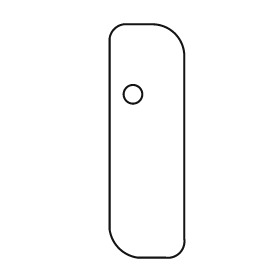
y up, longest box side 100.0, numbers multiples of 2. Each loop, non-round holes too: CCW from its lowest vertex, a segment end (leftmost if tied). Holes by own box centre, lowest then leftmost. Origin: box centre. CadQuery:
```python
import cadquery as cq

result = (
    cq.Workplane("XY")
    .moveTo(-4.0, -50.0)
    .lineTo(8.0, -50.0)
    .threePointArc((14.0, -48.0), (16.0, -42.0))
    .lineTo(16.0, 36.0)
    .threePointArc((12.0, 46.0), (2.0, 50.0))
    .lineTo(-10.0, 50.0)
    .threePointArc((-14.0, 48.0), (-16.0, 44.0))
    .lineTo(-16.0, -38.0)
    .threePointArc((-12.0, -46.0), (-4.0, -50.0))
    .close()
    .moveTo(-6.0, 20.0)
    .circle(4.0)
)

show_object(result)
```